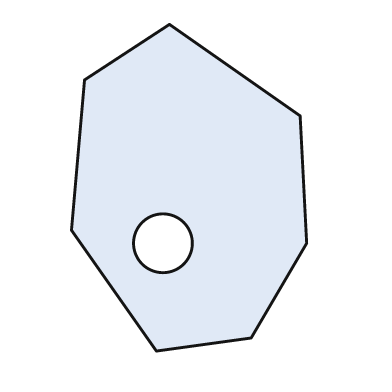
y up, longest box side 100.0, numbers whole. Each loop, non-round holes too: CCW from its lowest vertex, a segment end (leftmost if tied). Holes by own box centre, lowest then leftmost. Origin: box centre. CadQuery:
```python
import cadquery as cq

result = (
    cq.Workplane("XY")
    .moveTo(-10.0, -50.0)
    .lineTo(19.0, -46.0)
    .lineTo(36.0, -17.0)
    .lineTo(34.0, 22.0)
    .lineTo(-6.0, 50.0)
    .lineTo(-32.0, 33.0)
    .lineTo(-36.0, -13.0)
    .close()
    .moveTo(-8.0, -17.0)
    .circle(9.0)
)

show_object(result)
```